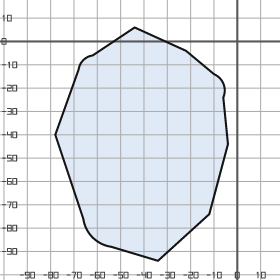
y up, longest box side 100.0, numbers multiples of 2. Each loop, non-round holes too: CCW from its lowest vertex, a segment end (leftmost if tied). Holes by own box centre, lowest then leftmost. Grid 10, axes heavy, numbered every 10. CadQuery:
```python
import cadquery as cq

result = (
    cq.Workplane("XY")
    .moveTo(-34.0, -94.0)
    .lineTo(-12.0, -74.0)
    .lineTo(-4.0, -44.0)
    .lineTo(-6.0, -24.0)
    .threePointArc((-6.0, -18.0), (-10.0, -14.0))
    .lineTo(-22.0, -4.0)
    .lineTo(-44.0, 6.0)
    .lineTo(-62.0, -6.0)
    .threePointArc((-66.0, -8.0), (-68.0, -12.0))
    .lineTo(-78.0, -40.0)
    .lineTo(-66.0, -76.0)
    .threePointArc((-62.0, -84.0), (-54.0, -88.0))
    .close()
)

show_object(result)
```